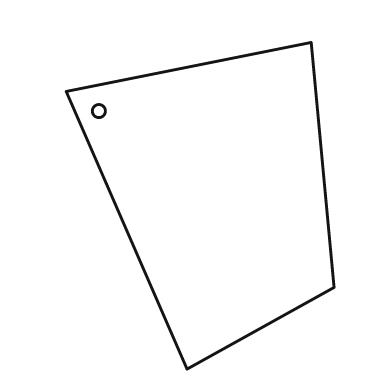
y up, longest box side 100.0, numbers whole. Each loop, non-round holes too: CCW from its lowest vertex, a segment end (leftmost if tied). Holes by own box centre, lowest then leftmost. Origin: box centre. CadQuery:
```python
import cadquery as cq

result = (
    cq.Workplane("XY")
    .moveTo(-4.0, -50.0)
    .lineTo(41.0, -25.0)
    .lineTo(34.0, 50.0)
    .lineTo(-41.0, 35.0)
    .close()
    .moveTo(-31.0, 29.0)
    .circle(2.0)
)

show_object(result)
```